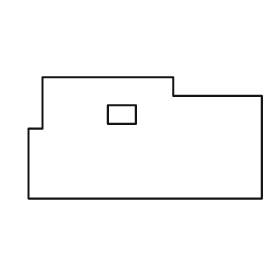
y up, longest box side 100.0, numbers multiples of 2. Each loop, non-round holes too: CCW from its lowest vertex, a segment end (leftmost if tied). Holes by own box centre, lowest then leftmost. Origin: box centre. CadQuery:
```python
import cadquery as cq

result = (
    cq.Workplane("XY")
    .moveTo(-50.0, -26.0)
    .lineTo(50.0, -26.0)
    .lineTo(50.0, 18.0)
    .lineTo(12.0, 18.0)
    .lineTo(12.0, 26.0)
    .lineTo(-44.0, 26.0)
    .lineTo(-44.0, 4.0)
    .lineTo(-50.0, 4.0)
    .close()
    .moveTo(-16.0, 6.0)
    .lineTo(-4.0, 6.0)
    .lineTo(-4.0, 14.0)
    .lineTo(-16.0, 14.0)
    .close()
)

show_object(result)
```